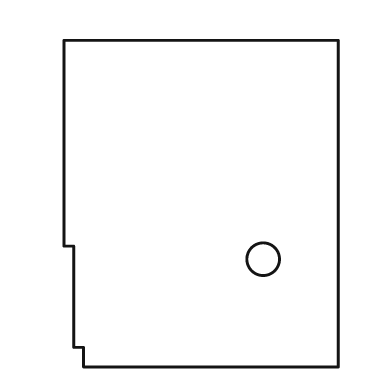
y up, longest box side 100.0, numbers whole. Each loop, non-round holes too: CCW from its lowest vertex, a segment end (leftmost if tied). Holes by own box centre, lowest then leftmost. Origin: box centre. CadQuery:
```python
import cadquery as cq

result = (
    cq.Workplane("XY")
    .moveTo(-36.0, -50.0)
    .lineTo(42.0, -50.0)
    .lineTo(42.0, 50.0)
    .lineTo(-42.0, 50.0)
    .lineTo(-42.0, -13.0)
    .lineTo(-39.0, -13.0)
    .lineTo(-39.0, -44.0)
    .lineTo(-36.0, -44.0)
    .close()
    .moveTo(19.0, -17.0)
    .circle(5.0)
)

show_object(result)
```